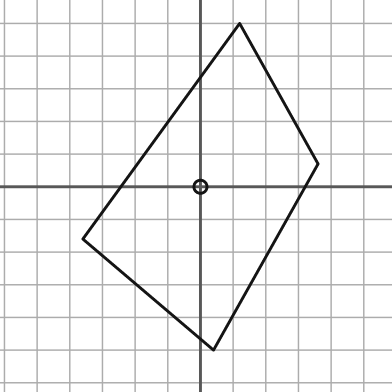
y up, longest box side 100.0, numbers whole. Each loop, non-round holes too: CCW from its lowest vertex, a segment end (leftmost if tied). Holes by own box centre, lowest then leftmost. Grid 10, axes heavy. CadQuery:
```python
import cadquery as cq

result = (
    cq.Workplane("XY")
    .moveTo(4.0, -50.0)
    .lineTo(36.0, 7.0)
    .lineTo(12.0, 50.0)
    .lineTo(-36.0, -16.0)
    .close()
    .moveTo(0.0, 0.0)
    .circle(2.0)
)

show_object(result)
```